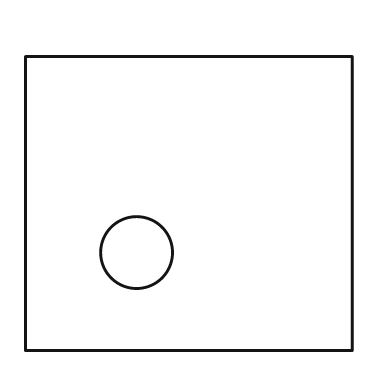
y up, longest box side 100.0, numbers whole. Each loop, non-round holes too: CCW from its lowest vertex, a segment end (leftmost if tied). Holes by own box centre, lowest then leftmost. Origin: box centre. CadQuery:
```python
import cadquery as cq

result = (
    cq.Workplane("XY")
    .moveTo(-50.0, -45.0)
    .lineTo(50.0, -45.0)
    .lineTo(50.0, 45.0)
    .lineTo(-50.0, 45.0)
    .close()
    .moveTo(-16.0, -15.0)
    .circle(11.0)
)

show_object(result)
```